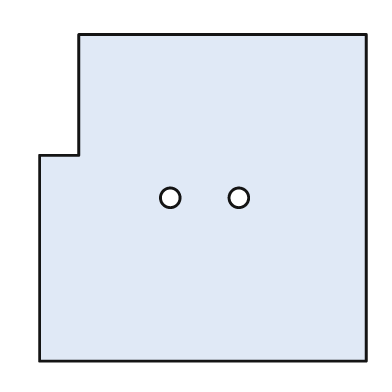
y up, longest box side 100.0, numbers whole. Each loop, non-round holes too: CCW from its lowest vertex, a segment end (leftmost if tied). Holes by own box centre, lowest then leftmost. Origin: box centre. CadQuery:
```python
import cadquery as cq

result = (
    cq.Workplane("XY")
    .moveTo(-50.0, -50.0)
    .lineTo(50.0, -50.0)
    .lineTo(50.0, 50.0)
    .lineTo(-38.0, 50.0)
    .lineTo(-38.0, 13.0)
    .lineTo(-50.0, 13.0)
    .close()
    .moveTo(-10.0, 0.0)
    .circle(3.0)
    .moveTo(11.0, 0.0)
    .circle(3.0)
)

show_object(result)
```